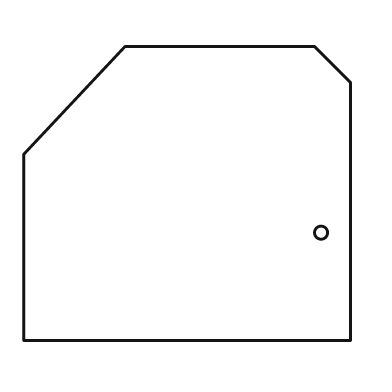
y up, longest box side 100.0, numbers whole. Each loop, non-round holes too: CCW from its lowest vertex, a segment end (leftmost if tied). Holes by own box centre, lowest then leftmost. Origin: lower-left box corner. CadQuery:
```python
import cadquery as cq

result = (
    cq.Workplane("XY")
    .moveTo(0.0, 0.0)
    .lineTo(100.0, 0.0)
    .lineTo(100.0, 79.0)
    .lineTo(89.0, 90.0)
    .lineTo(31.0, 90.0)
    .lineTo(0.0, 57.0)
    .close()
    .moveTo(91.0, 33.0)
    .circle(2.0)
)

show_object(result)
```